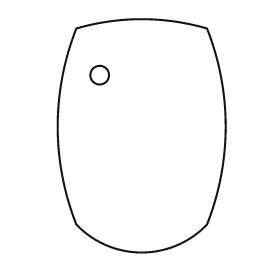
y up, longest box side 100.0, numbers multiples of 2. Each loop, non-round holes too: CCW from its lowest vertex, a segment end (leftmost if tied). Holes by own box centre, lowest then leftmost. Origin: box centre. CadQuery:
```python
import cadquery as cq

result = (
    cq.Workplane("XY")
    .moveTo(-28.0, -38.0)
    .threePointArc((0.0, -50.0), (28.0, -38.0))
    .threePointArc((36.0, 4.0), (28.0, 46.0))
    .threePointArc((0.0, 50.0), (-28.0, 46.0))
    .threePointArc((-36.0, 4.0), (-28.0, -38.0))
    .close()
    .moveTo(-18.0, 26.0)
    .circle(4.0)
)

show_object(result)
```